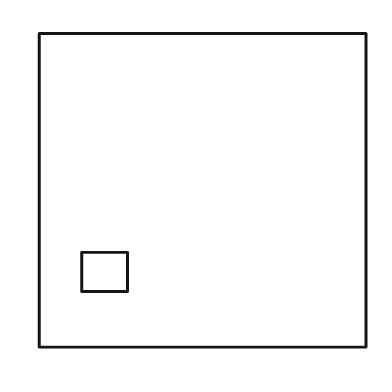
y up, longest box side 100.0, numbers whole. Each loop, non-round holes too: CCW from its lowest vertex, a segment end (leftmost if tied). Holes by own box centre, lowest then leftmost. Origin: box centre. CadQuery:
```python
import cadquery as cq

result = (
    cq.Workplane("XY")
    .moveTo(-50.0, -48.0)
    .lineTo(50.0, -48.0)
    .lineTo(50.0, 48.0)
    .lineTo(-50.0, 48.0)
    .close()
    .moveTo(-37.0, -31.0)
    .lineTo(-23.0, -31.0)
    .lineTo(-23.0, -19.0)
    .lineTo(-37.0, -19.0)
    .close()
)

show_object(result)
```